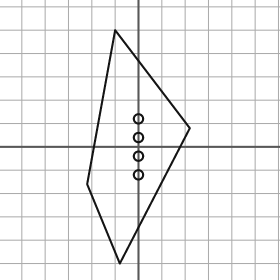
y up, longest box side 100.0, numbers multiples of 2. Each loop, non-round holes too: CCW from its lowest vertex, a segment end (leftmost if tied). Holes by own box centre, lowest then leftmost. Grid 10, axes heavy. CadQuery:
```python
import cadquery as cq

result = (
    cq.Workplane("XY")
    .moveTo(-8.0, -50.0)
    .lineTo(22.0, 8.0)
    .lineTo(-10.0, 50.0)
    .lineTo(-22.0, -16.0)
    .close()
    .moveTo(0.0, -12.0)
    .circle(2.0)
    .moveTo(0.0, -4.0)
    .circle(2.0)
    .moveTo(0.0, 4.0)
    .circle(2.0)
    .moveTo(0.0, 12.0)
    .circle(2.0)
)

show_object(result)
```